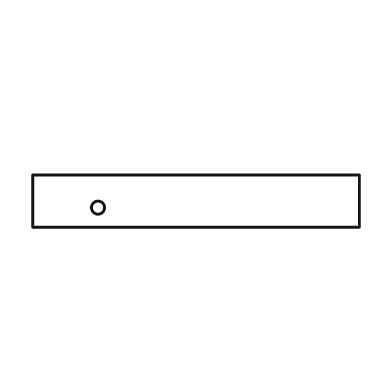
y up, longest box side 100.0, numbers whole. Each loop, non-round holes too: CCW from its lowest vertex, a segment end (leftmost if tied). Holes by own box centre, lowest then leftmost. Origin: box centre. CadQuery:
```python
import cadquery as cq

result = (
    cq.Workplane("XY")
    .moveTo(-50.0, -8.0)
    .lineTo(50.0, -8.0)
    .lineTo(50.0, 8.0)
    .lineTo(-50.0, 8.0)
    .close()
    .moveTo(-30.0, -2.0)
    .circle(2.0)
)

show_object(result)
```